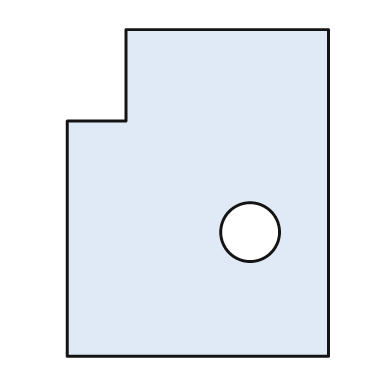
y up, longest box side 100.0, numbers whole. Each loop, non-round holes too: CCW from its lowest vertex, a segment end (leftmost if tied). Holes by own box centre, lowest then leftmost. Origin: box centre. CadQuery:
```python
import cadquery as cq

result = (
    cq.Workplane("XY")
    .moveTo(-40.0, -50.0)
    .lineTo(40.0, -50.0)
    .lineTo(40.0, 50.0)
    .lineTo(-22.0, 50.0)
    .lineTo(-22.0, 22.0)
    .lineTo(-40.0, 22.0)
    .close()
    .moveTo(16.0, -12.0)
    .circle(9.0)
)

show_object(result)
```